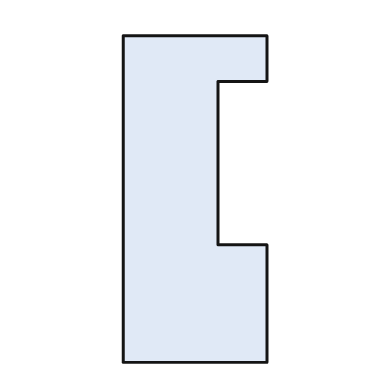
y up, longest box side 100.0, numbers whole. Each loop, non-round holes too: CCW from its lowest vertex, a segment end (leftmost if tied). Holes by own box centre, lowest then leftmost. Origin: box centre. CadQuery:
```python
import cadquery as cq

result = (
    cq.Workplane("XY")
    .moveTo(-22.0, -50.0)
    .lineTo(22.0, -50.0)
    .lineTo(22.0, -14.0)
    .lineTo(7.0, -14.0)
    .lineTo(7.0, 36.0)
    .lineTo(22.0, 36.0)
    .lineTo(22.0, 50.0)
    .lineTo(-22.0, 50.0)
    .close()
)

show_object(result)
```